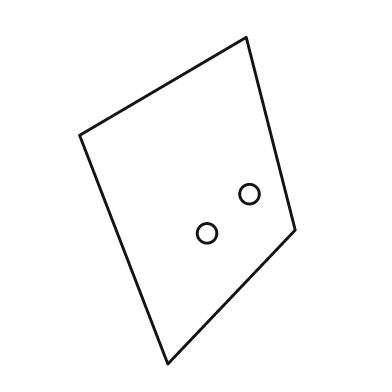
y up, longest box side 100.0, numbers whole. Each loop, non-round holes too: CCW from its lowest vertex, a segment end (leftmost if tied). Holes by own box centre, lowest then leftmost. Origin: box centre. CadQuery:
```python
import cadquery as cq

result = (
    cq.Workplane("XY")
    .moveTo(-6.0, -50.0)
    .lineTo(33.0, -9.0)
    .lineTo(18.0, 50.0)
    .lineTo(-33.0, 20.0)
    .close()
    .moveTo(6.0, -10.0)
    .circle(3.0)
    .moveTo(19.0, 2.0)
    .circle(3.0)
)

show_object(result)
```